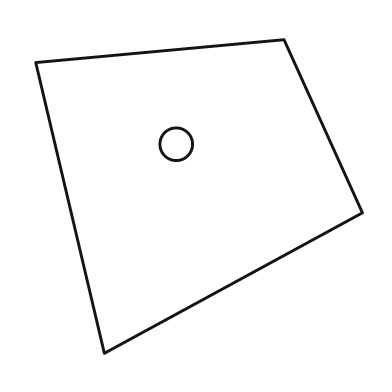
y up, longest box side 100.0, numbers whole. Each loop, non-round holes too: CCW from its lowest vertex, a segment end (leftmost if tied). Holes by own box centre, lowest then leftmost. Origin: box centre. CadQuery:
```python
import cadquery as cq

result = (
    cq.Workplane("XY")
    .moveTo(-29.0, -48.0)
    .lineTo(50.0, -5.0)
    .lineTo(26.0, 48.0)
    .lineTo(-50.0, 41.0)
    .close()
    .moveTo(-7.0, 16.0)
    .circle(5.0)
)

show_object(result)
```